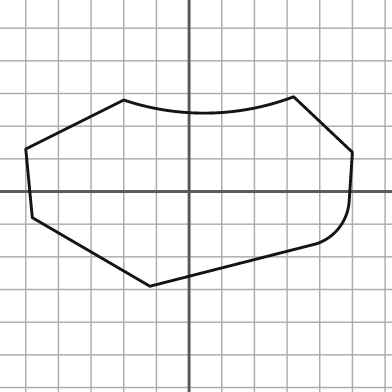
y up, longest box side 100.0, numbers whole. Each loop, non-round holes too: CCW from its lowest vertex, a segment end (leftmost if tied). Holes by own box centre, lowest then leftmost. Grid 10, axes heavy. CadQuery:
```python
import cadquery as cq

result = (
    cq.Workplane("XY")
    .moveTo(-12.0, -29.0)
    .lineTo(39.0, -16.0)
    .threePointArc((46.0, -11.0), (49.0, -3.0))
    .lineTo(50.0, 12.0)
    .lineTo(32.0, 29.0)
    .threePointArc((6.0, 24.0), (-20.0, 28.0))
    .lineTo(-50.0, 13.0)
    .lineTo(-48.0, -8.0)
    .close()
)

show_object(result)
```